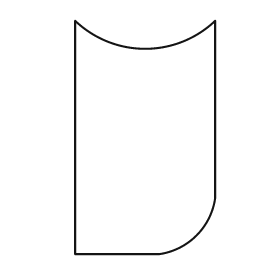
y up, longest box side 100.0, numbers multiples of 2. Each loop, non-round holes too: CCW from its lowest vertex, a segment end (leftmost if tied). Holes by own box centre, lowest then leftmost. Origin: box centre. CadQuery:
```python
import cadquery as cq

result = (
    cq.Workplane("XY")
    .moveTo(-30.0, -50.0)
    .lineTo(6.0, -50.0)
    .threePointArc((22.0, -42.0), (30.0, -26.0))
    .lineTo(30.0, 50.0)
    .threePointArc((0.0, 38.0), (-30.0, 50.0))
    .close()
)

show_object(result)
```